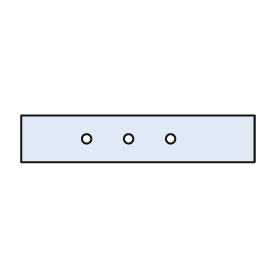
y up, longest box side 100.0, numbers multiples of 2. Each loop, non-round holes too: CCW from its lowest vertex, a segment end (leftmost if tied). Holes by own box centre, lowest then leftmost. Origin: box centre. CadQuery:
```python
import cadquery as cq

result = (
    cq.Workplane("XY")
    .moveTo(-50.0, -10.0)
    .lineTo(50.0, -10.0)
    .lineTo(50.0, 10.0)
    .lineTo(-50.0, 10.0)
    .close()
    .moveTo(-22.0, 0.0)
    .circle(2.0)
    .moveTo(-4.0, 0.0)
    .circle(2.0)
    .moveTo(14.0, 0.0)
    .circle(2.0)
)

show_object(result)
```